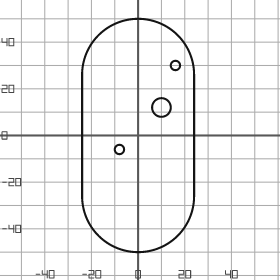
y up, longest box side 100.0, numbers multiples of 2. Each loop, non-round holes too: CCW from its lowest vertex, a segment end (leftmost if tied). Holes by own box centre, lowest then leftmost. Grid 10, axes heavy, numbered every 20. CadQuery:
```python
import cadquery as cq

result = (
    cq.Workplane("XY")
    .moveTo(-24.0, -26.0)
    .threePointArc((0.0, -50.0), (24.0, -26.0))
    .lineTo(24.0, 26.0)
    .threePointArc((0.0, 50.0), (-24.0, 26.0))
    .close()
    .moveTo(-8.0, -6.0)
    .circle(2.0)
    .moveTo(10.0, 12.0)
    .circle(4.0)
    .moveTo(16.0, 30.0)
    .circle(2.0)
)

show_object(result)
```